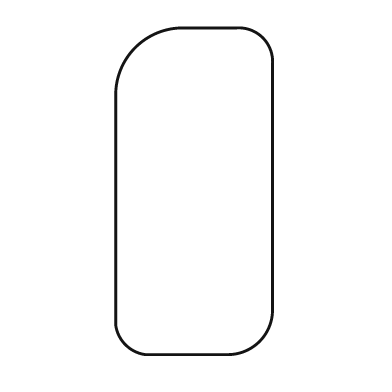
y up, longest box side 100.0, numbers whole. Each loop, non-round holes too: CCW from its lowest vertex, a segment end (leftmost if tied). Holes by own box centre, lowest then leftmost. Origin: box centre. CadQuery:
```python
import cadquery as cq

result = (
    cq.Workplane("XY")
    .moveTo(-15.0, -50.0)
    .lineTo(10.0, -50.0)
    .threePointArc((20.0, -46.0), (24.0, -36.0))
    .lineTo(24.0, 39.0)
    .threePointArc((21.0, 47.0), (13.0, 50.0))
    .lineTo(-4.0, 50.0)
    .threePointArc((-18.0, 44.0), (-24.0, 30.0))
    .lineTo(-24.0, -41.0)
    .threePointArc((-21.0, -47.0), (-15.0, -50.0))
    .close()
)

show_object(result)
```